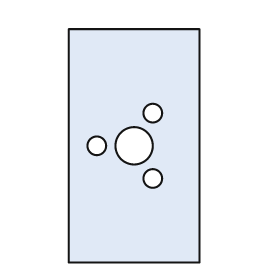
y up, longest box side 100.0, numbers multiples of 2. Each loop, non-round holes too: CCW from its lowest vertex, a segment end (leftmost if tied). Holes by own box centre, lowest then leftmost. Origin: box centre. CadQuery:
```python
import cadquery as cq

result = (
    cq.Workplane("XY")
    .moveTo(-28.0, -50.0)
    .lineTo(28.0, -50.0)
    .lineTo(28.0, 50.0)
    .lineTo(-28.0, 50.0)
    .close()
    .moveTo(8.0, -14.0)
    .circle(4.0)
    .moveTo(-16.0, 0.0)
    .circle(4.0)
    .moveTo(0.0, 0.0)
    .circle(8.0)
    .moveTo(8.0, 14.0)
    .circle(4.0)
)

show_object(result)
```